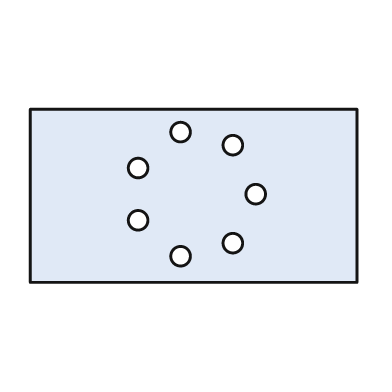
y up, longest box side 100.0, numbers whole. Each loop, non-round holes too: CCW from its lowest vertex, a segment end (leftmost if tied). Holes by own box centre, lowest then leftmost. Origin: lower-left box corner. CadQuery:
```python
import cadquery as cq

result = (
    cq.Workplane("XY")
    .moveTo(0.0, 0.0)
    .lineTo(100.0, 0.0)
    .lineTo(100.0, 53.0)
    .lineTo(0.0, 53.0)
    .close()
    .moveTo(46.0, 8.0)
    .circle(3.0)
    .moveTo(62.0, 12.0)
    .circle(3.0)
    .moveTo(33.0, 19.0)
    .circle(3.0)
    .moveTo(69.0, 27.0)
    .circle(3.0)
    .moveTo(33.0, 35.0)
    .circle(3.0)
    .moveTo(62.0, 42.0)
    .circle(3.0)
    .moveTo(46.0, 46.0)
    .circle(3.0)
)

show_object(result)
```